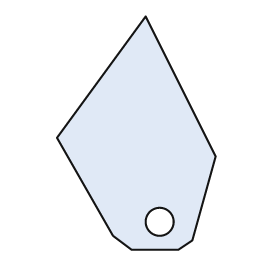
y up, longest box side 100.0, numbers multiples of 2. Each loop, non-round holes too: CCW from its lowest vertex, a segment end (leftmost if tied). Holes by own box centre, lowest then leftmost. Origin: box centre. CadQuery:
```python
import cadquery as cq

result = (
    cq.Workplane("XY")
    .moveTo(-2.0, -50.0)
    .lineTo(18.0, -50.0)
    .lineTo(24.0, -46.0)
    .lineTo(34.0, -10.0)
    .lineTo(4.0, 50.0)
    .lineTo(-34.0, -2.0)
    .lineTo(-10.0, -44.0)
    .close()
    .moveTo(10.0, -38.0)
    .circle(6.0)
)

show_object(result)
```